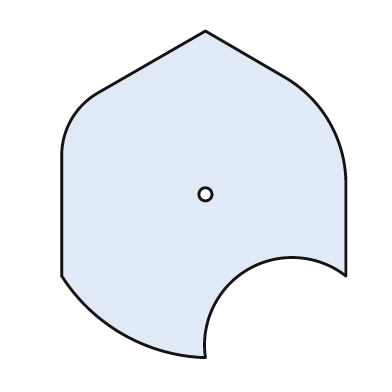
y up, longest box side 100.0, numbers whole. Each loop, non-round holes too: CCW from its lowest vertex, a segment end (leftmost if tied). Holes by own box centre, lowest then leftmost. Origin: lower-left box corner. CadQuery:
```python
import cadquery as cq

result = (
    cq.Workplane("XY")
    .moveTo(44.0, 0.0)
    .threePointArc((57.0, 27.0), (87.0, 25.0))
    .lineTo(87.0, 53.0)
    .threePointArc((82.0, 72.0), (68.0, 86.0))
    .lineTo(44.0, 100.0)
    .lineTo(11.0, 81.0)
    .threePointArc((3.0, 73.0), (0.0, 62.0))
    .lineTo(0.0, 25.0)
    .threePointArc((19.0, 7.0), (44.0, 0.0))
    .close()
    .moveTo(44.0, 50.0)
    .circle(2.0)
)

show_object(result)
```